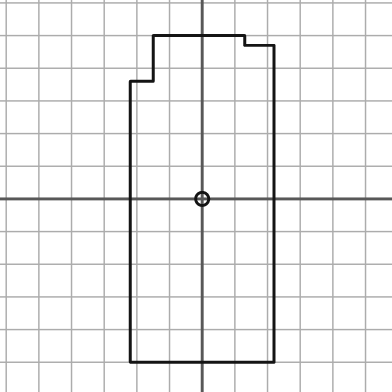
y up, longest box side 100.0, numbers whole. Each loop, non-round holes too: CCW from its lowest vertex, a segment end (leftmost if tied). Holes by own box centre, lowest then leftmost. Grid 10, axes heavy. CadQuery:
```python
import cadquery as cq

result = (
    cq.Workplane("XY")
    .moveTo(-22.0, -50.0)
    .lineTo(22.0, -50.0)
    .lineTo(22.0, 47.0)
    .lineTo(13.0, 47.0)
    .lineTo(13.0, 50.0)
    .lineTo(-15.0, 50.0)
    .lineTo(-15.0, 36.0)
    .lineTo(-22.0, 36.0)
    .close()
    .moveTo(0.0, 0.0)
    .circle(2.0)
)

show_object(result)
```